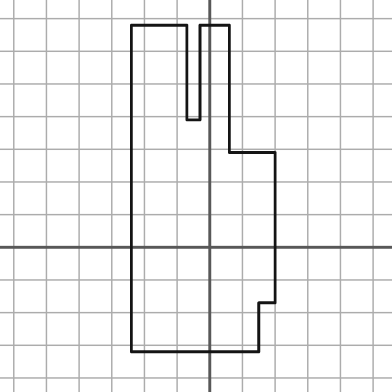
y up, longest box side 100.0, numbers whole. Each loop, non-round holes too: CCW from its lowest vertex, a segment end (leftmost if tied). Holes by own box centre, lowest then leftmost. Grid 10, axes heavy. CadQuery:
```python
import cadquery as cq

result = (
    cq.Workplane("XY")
    .moveTo(-24.0, -32.0)
    .lineTo(15.0, -32.0)
    .lineTo(15.0, -17.0)
    .lineTo(20.0, -17.0)
    .lineTo(20.0, 29.0)
    .lineTo(6.0, 29.0)
    .lineTo(6.0, 68.0)
    .lineTo(-3.0, 68.0)
    .lineTo(-3.0, 39.0)
    .lineTo(-7.0, 39.0)
    .lineTo(-7.0, 68.0)
    .lineTo(-24.0, 68.0)
    .close()
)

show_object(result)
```